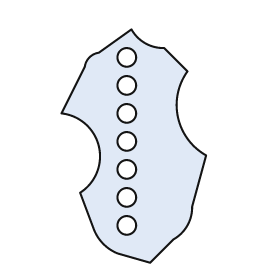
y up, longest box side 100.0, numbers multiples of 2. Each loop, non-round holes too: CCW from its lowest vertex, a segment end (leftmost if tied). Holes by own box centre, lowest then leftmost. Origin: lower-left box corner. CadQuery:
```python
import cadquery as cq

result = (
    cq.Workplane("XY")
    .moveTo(38.0, 0.0)
    .lineTo(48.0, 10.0)
    .threePointArc((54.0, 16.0), (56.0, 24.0))
    .lineTo(62.0, 46.0)
    .threePointArc((50.0, 62.0), (54.0, 82.0))
    .lineTo(44.0, 92.0)
    .threePointArc((36.0, 94.0), (30.0, 100.0))
    .lineTo(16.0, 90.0)
    .threePointArc((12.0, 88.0), (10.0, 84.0))
    .lineTo(0.0, 64.0)
    .threePointArc((16.0, 50.0), (8.0, 30.0))
    .lineTo(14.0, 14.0)
    .threePointArc((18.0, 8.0), (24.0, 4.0))
    .close()
    .moveTo(28.0, 16.0)
    .circle(4.0)
    .moveTo(28.0, 28.0)
    .circle(4.0)
    .moveTo(28.0, 40.0)
    .circle(4.0)
    .moveTo(28.0, 52.0)
    .circle(4.0)
    .moveTo(28.0, 64.0)
    .circle(4.0)
    .moveTo(28.0, 76.0)
    .circle(4.0)
    .moveTo(28.0, 88.0)
    .circle(4.0)
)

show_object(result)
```